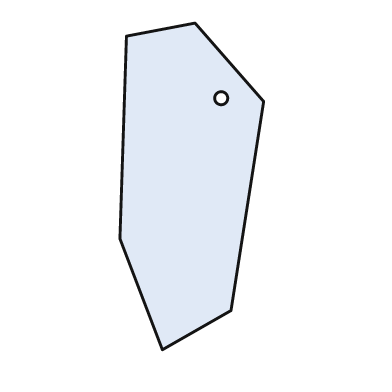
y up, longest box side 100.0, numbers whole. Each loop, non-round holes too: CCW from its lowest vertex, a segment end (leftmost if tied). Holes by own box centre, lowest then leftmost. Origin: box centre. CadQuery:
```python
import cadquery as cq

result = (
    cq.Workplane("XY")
    .moveTo(-9.0, -50.0)
    .lineTo(12.0, -38.0)
    .lineTo(22.0, 26.0)
    .lineTo(1.0, 50.0)
    .lineTo(-20.0, 46.0)
    .lineTo(-22.0, -16.0)
    .close()
    .moveTo(9.0, 27.0)
    .circle(2.0)
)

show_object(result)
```